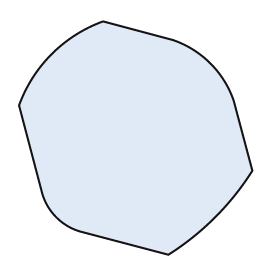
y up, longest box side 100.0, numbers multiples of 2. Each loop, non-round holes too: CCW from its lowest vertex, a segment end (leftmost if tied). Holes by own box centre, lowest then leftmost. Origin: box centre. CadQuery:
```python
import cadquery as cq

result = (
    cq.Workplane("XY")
    .moveTo(14.0, -50.0)
    .threePointArc((34.0, -34.0), (50.0, -14.0))
    .lineTo(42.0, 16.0)
    .threePointArc((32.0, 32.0), (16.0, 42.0))
    .lineTo(-14.0, 50.0)
    .threePointArc((-36.0, 36.0), (-50.0, 14.0))
    .lineTo(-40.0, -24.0)
    .threePointArc((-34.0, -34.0), (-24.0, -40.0))
    .close()
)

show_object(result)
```